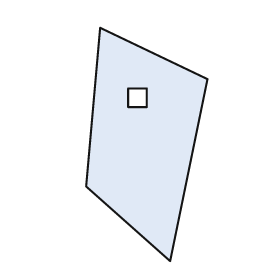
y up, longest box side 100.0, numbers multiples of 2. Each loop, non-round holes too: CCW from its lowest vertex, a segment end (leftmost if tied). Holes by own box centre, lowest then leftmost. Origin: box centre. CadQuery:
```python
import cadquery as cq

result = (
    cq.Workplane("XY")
    .moveTo(10.0, -50.0)
    .lineTo(26.0, 28.0)
    .lineTo(-20.0, 50.0)
    .lineTo(-26.0, -18.0)
    .close()
    .moveTo(-8.0, 16.0)
    .lineTo(0.0, 16.0)
    .lineTo(0.0, 24.0)
    .lineTo(-8.0, 24.0)
    .close()
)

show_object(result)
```